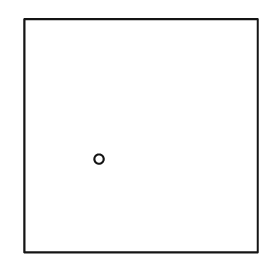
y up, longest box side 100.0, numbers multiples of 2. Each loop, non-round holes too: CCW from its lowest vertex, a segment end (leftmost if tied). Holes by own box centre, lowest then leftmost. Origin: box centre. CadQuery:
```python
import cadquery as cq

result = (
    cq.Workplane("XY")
    .moveTo(-50.0, -50.0)
    .lineTo(50.0, -50.0)
    .lineTo(50.0, 50.0)
    .lineTo(-50.0, 50.0)
    .close()
    .moveTo(-18.0, -10.0)
    .circle(2.0)
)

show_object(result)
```